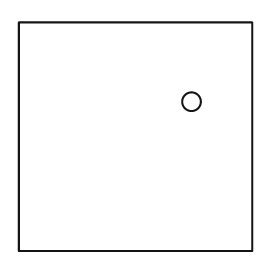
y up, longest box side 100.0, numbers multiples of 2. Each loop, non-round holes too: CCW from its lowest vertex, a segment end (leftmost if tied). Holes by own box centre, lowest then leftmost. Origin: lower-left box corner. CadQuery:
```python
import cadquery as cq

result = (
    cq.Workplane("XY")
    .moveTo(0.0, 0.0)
    .lineTo(100.0, 0.0)
    .lineTo(100.0, 98.0)
    .lineTo(0.0, 98.0)
    .close()
    .moveTo(74.0, 64.0)
    .circle(4.0)
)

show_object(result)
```